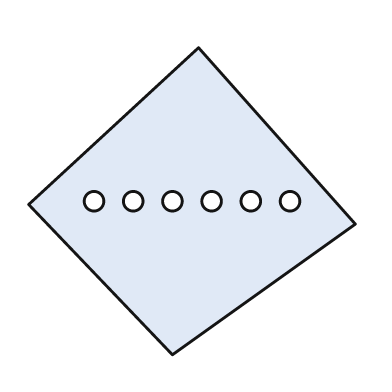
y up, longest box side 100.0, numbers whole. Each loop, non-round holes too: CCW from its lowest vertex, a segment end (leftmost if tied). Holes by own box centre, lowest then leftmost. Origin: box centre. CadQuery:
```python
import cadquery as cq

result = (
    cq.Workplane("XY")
    .moveTo(-6.0, -47.0)
    .lineTo(50.0, -7.0)
    .lineTo(2.0, 47.0)
    .lineTo(-50.0, -1.0)
    .close()
    .moveTo(-30.0, 0.0)
    .circle(3.0)
    .moveTo(-18.0, 0.0)
    .circle(3.0)
    .moveTo(-6.0, 0.0)
    .circle(3.0)
    .moveTo(6.0, 0.0)
    .circle(3.0)
    .moveTo(18.0, 0.0)
    .circle(3.0)
    .moveTo(30.0, 0.0)
    .circle(3.0)
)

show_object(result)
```